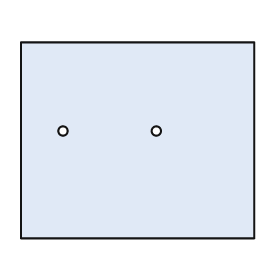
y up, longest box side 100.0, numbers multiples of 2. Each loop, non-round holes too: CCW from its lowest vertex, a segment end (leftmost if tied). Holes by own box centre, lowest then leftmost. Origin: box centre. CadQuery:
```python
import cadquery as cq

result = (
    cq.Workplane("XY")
    .moveTo(-50.0, -42.0)
    .lineTo(50.0, -42.0)
    .lineTo(50.0, 42.0)
    .lineTo(-50.0, 42.0)
    .close()
    .moveTo(-32.0, 4.0)
    .circle(2.0)
    .moveTo(8.0, 4.0)
    .circle(2.0)
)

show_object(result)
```